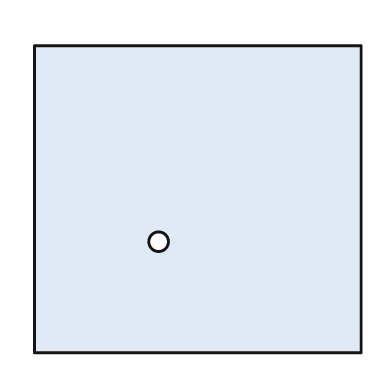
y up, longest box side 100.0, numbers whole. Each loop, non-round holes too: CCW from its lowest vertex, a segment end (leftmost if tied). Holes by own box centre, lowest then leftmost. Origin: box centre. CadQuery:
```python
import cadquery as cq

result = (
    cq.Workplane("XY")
    .moveTo(-50.0, -47.0)
    .lineTo(50.0, -47.0)
    .lineTo(50.0, 47.0)
    .lineTo(-50.0, 47.0)
    .close()
    .moveTo(-12.0, -13.0)
    .circle(3.0)
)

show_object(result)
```